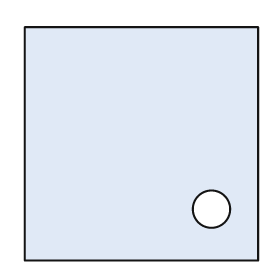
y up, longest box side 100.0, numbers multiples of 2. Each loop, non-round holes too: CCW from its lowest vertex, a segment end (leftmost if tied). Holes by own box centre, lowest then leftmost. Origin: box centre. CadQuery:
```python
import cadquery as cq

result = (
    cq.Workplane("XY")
    .moveTo(-50.0, -50.0)
    .lineTo(50.0, -50.0)
    .lineTo(50.0, 50.0)
    .lineTo(-50.0, 50.0)
    .close()
    .moveTo(30.0, -28.0)
    .circle(8.0)
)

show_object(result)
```